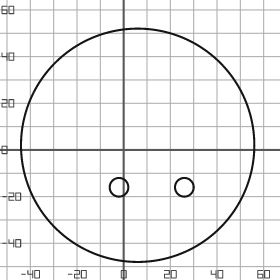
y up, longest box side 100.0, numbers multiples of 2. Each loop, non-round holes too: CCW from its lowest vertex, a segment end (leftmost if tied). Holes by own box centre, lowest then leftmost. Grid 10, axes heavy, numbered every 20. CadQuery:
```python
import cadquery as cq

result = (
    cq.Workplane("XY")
    .moveTo(6.0, 2.0)
    .circle(50.0)
    .moveTo(-2.0, -16.0)
    .circle(4.0)
    .moveTo(26.0, -16.0)
    .circle(4.0)
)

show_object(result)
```